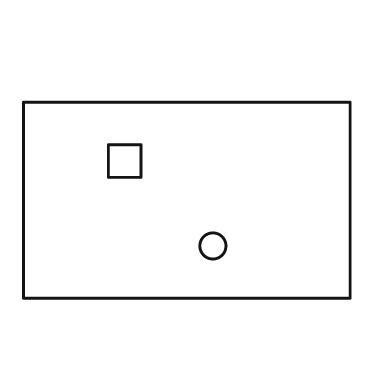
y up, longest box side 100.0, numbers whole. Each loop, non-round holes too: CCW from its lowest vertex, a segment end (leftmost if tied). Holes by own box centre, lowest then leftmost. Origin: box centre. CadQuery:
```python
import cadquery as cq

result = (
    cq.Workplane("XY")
    .moveTo(-50.0, -30.0)
    .lineTo(50.0, -30.0)
    .lineTo(50.0, 30.0)
    .lineTo(-50.0, 30.0)
    .close()
    .moveTo(8.0, -14.0)
    .circle(4.0)
    .moveTo(-24.0, 7.0)
    .lineTo(-14.0, 7.0)
    .lineTo(-14.0, 17.0)
    .lineTo(-24.0, 17.0)
    .close()
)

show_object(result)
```